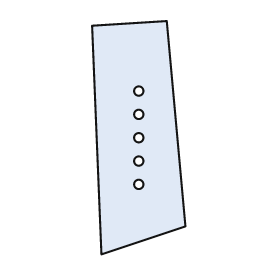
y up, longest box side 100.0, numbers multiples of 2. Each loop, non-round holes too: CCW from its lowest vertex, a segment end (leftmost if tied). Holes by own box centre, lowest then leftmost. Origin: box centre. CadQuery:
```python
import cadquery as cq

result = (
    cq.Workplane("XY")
    .moveTo(-16.0, -50.0)
    .lineTo(20.0, -38.0)
    .lineTo(12.0, 50.0)
    .lineTo(-20.0, 48.0)
    .close()
    .moveTo(0.0, -20.0)
    .circle(2.0)
    .moveTo(0.0, -10.0)
    .circle(2.0)
    .moveTo(0.0, 0.0)
    .circle(2.0)
    .moveTo(0.0, 10.0)
    .circle(2.0)
    .moveTo(0.0, 20.0)
    .circle(2.0)
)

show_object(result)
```